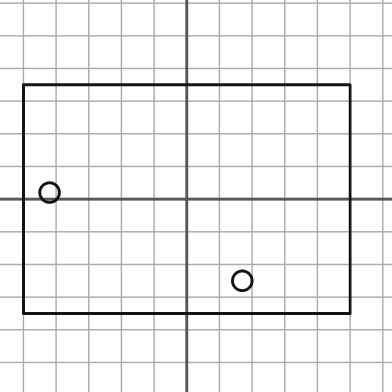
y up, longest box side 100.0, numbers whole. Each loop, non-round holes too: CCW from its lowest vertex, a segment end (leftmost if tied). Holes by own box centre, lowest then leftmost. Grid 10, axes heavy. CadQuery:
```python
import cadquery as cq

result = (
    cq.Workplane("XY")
    .moveTo(-50.0, -35.0)
    .lineTo(50.0, -35.0)
    .lineTo(50.0, 35.0)
    .lineTo(-50.0, 35.0)
    .close()
    .moveTo(17.0, -25.0)
    .circle(3.0)
    .moveTo(-42.0, 2.0)
    .circle(3.0)
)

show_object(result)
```